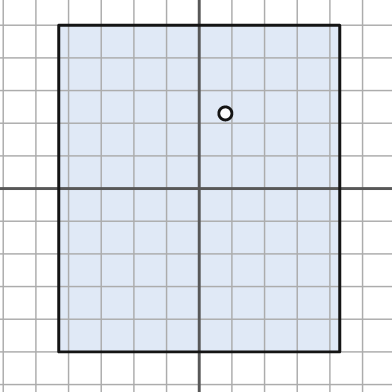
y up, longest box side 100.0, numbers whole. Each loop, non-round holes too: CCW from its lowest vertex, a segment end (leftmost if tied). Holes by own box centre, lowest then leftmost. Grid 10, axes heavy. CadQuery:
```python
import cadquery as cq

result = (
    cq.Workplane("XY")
    .moveTo(-43.0, -50.0)
    .lineTo(43.0, -50.0)
    .lineTo(43.0, 50.0)
    .lineTo(-43.0, 50.0)
    .close()
    .moveTo(8.0, 23.0)
    .circle(2.0)
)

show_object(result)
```